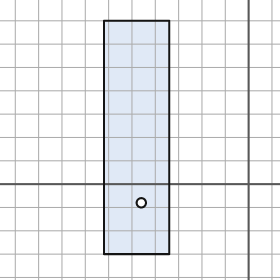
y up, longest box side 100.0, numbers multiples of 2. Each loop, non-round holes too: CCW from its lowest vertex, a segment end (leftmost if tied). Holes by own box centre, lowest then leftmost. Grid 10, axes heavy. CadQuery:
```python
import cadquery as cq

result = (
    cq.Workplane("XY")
    .moveTo(-62.0, -30.0)
    .lineTo(-34.0, -30.0)
    .lineTo(-34.0, 70.0)
    .lineTo(-62.0, 70.0)
    .close()
    .moveTo(-46.0, -8.0)
    .circle(2.0)
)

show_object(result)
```